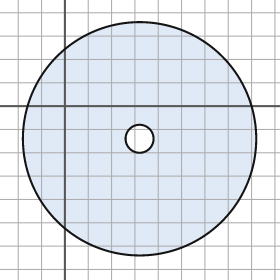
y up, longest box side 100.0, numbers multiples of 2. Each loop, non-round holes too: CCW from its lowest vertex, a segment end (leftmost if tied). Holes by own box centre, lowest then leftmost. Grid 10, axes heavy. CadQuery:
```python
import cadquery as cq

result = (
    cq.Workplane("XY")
    .moveTo(32.0, -14.0)
    .circle(50.0)
    .moveTo(32.0, -14.0)
    .circle(6.0)
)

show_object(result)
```